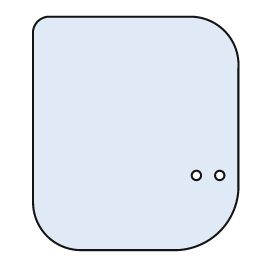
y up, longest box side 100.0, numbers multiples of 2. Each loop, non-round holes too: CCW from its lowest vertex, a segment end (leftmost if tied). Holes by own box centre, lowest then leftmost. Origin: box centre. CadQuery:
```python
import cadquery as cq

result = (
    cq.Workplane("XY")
    .moveTo(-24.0, -50.0)
    .lineTo(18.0, -50.0)
    .threePointArc((36.0, -42.0), (44.0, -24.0))
    .lineTo(44.0, 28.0)
    .threePointArc((38.0, 44.0), (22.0, 50.0))
    .lineTo(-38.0, 50.0)
    .threePointArc((-42.0, 48.0), (-44.0, 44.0))
    .lineTo(-44.0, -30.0)
    .threePointArc((-38.0, -44.0), (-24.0, -50.0))
    .close()
    .moveTo(26.0, -18.0)
    .circle(2.0)
    .moveTo(36.0, -18.0)
    .circle(2.0)
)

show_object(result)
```